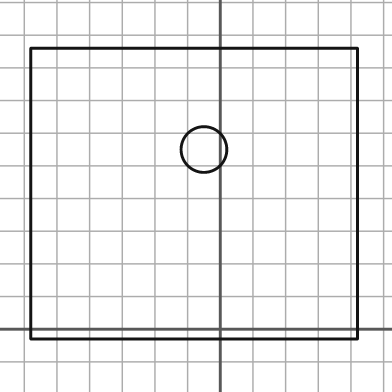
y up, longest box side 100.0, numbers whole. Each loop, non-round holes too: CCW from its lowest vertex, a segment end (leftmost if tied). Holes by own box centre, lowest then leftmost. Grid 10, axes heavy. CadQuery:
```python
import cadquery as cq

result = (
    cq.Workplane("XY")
    .moveTo(-58.0, -3.0)
    .lineTo(42.0, -3.0)
    .lineTo(42.0, 86.0)
    .lineTo(-58.0, 86.0)
    .close()
    .moveTo(-5.0, 55.0)
    .circle(7.0)
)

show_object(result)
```